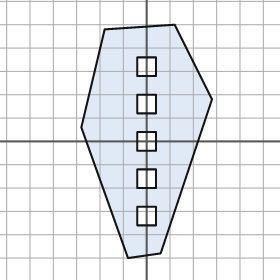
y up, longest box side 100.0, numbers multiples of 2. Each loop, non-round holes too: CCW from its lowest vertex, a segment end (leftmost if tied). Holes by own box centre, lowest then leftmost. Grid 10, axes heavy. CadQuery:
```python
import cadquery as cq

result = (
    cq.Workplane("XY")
    .moveTo(-8.0, -50.0)
    .lineTo(6.0, -48.0)
    .lineTo(28.0, 18.0)
    .lineTo(12.0, 50.0)
    .lineTo(-18.0, 48.0)
    .lineTo(-28.0, 6.0)
    .close()
    .moveTo(-4.0, -36.0)
    .lineTo(4.0, -36.0)
    .lineTo(4.0, -28.0)
    .lineTo(-4.0, -28.0)
    .close()
    .moveTo(-4.0, -20.0)
    .lineTo(4.0, -20.0)
    .lineTo(4.0, -12.0)
    .lineTo(-4.0, -12.0)
    .close()
    .moveTo(-4.0, -4.0)
    .lineTo(4.0, -4.0)
    .lineTo(4.0, 4.0)
    .lineTo(-4.0, 4.0)
    .close()
    .moveTo(-4.0, 12.0)
    .lineTo(4.0, 12.0)
    .lineTo(4.0, 20.0)
    .lineTo(-4.0, 20.0)
    .close()
    .moveTo(-4.0, 28.0)
    .lineTo(4.0, 28.0)
    .lineTo(4.0, 36.0)
    .lineTo(-4.0, 36.0)
    .close()
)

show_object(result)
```